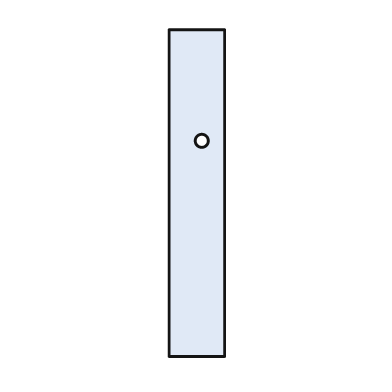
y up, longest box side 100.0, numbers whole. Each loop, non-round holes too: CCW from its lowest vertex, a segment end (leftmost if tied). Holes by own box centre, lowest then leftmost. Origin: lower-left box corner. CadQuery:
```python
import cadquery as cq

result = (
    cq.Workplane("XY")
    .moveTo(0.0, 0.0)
    .lineTo(17.0, 0.0)
    .lineTo(17.0, 100.0)
    .lineTo(0.0, 100.0)
    .close()
    .moveTo(10.0, 66.0)
    .circle(2.0)
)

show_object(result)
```